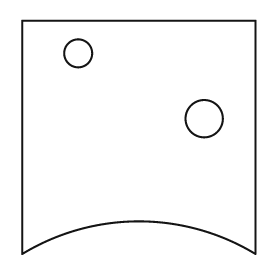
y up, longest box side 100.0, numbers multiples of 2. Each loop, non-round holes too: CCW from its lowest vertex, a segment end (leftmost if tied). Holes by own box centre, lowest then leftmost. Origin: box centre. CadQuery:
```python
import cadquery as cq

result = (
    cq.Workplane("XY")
    .moveTo(-50.0, -50.0)
    .threePointArc((0.0, -36.0), (50.0, -50.0))
    .lineTo(50.0, 50.0)
    .lineTo(-50.0, 50.0)
    .close()
    .moveTo(28.0, 8.0)
    .circle(8.0)
    .moveTo(-26.0, 36.0)
    .circle(6.0)
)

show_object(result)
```